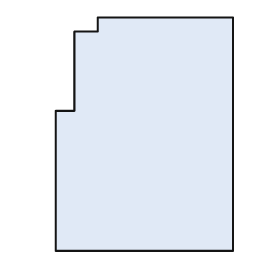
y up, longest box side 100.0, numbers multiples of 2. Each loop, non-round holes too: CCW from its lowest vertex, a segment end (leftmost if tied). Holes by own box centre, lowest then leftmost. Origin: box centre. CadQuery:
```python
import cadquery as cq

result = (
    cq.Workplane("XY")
    .moveTo(-38.0, -50.0)
    .lineTo(38.0, -50.0)
    .lineTo(38.0, 50.0)
    .lineTo(-20.0, 50.0)
    .lineTo(-20.0, 44.0)
    .lineTo(-30.0, 44.0)
    .lineTo(-30.0, 10.0)
    .lineTo(-38.0, 10.0)
    .close()
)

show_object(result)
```